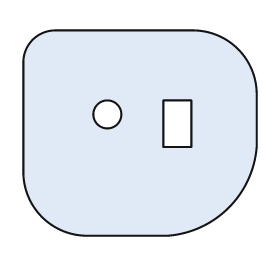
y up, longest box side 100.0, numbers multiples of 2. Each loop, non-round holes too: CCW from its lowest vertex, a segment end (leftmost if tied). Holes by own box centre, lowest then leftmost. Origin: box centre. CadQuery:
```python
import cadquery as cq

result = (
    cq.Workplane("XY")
    .moveTo(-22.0, -44.0)
    .lineTo(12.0, -44.0)
    .threePointArc((38.0, -32.0), (50.0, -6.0))
    .lineTo(50.0, 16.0)
    .threePointArc((42.0, 36.0), (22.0, 44.0))
    .lineTo(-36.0, 44.0)
    .threePointArc((-46.0, 40.0), (-50.0, 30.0))
    .lineTo(-50.0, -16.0)
    .threePointArc((-42.0, -36.0), (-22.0, -44.0))
    .close()
    .moveTo(10.0, -6.0)
    .lineTo(22.0, -6.0)
    .lineTo(22.0, 14.0)
    .lineTo(10.0, 14.0)
    .close()
    .moveTo(-14.0, 8.0)
    .circle(6.0)
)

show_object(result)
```